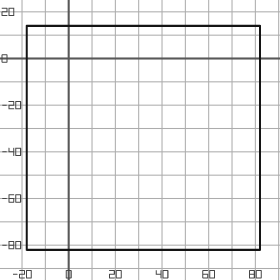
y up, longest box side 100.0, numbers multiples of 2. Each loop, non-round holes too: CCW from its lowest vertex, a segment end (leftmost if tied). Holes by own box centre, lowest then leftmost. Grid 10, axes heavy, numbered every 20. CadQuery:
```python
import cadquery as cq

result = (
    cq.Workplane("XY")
    .moveTo(-18.0, -82.0)
    .lineTo(82.0, -82.0)
    .lineTo(82.0, 14.0)
    .lineTo(-18.0, 14.0)
    .close()
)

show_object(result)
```